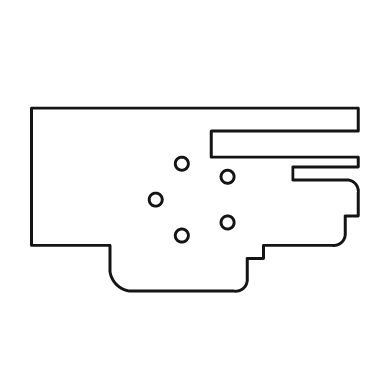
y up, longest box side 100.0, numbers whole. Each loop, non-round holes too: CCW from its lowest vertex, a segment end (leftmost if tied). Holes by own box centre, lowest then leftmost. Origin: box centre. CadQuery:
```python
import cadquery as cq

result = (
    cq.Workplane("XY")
    .moveTo(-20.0, -28.0)
    .lineTo(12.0, -28.0)
    .threePointArc((15.0, -27.0), (16.0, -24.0))
    .lineTo(16.0, -18.0)
    .lineTo(21.0, -18.0)
    .lineTo(21.0, -14.0)
    .lineTo(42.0, -14.0)
    .threePointArc((45.0, -13.0), (46.0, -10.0))
    .lineTo(46.0, -5.0)
    .lineTo(50.0, -5.0)
    .lineTo(50.0, 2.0)
    .threePointArc((49.0, 5.0), (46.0, 6.0))
    .lineTo(30.0, 6.0)
    .lineTo(30.0, 10.0)
    .lineTo(50.0, 10.0)
    .lineTo(50.0, 13.0)
    .lineTo(5.0, 13.0)
    .lineTo(5.0, 21.0)
    .lineTo(50.0, 21.0)
    .lineTo(50.0, 28.0)
    .lineTo(-50.0, 28.0)
    .lineTo(-50.0, -14.0)
    .lineTo(-26.0, -14.0)
    .lineTo(-26.0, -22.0)
    .threePointArc((-24.0, -26.0), (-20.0, -28.0))
    .close()
    .moveTo(-4.0, -11.0)
    .circle(2.0)
    .moveTo(10.0, -7.0)
    .circle(2.0)
    .moveTo(-12.0, 0.0)
    .circle(2.0)
    .moveTo(10.0, 7.0)
    .circle(2.0)
    .moveTo(-4.0, 11.0)
    .circle(2.0)
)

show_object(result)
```